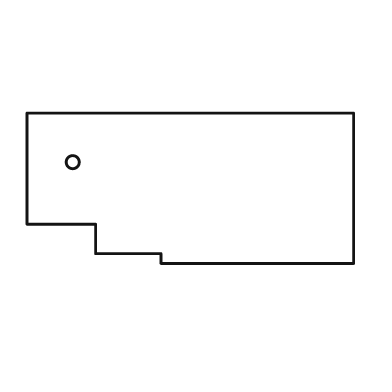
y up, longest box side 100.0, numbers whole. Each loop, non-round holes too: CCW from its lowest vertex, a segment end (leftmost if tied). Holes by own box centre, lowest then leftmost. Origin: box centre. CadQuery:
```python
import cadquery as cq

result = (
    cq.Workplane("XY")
    .moveTo(-9.0, -23.0)
    .lineTo(50.0, -23.0)
    .lineTo(50.0, 23.0)
    .lineTo(-50.0, 23.0)
    .lineTo(-50.0, -11.0)
    .lineTo(-29.0, -11.0)
    .lineTo(-29.0, -20.0)
    .lineTo(-9.0, -20.0)
    .close()
    .moveTo(-36.0, 8.0)
    .circle(2.0)
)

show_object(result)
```